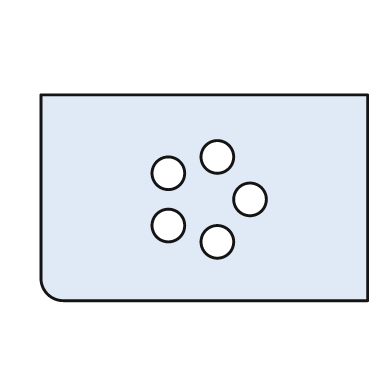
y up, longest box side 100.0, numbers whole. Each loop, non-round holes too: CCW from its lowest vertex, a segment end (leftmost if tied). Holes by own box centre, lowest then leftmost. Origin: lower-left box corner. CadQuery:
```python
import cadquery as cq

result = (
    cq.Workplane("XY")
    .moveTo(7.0, 0.0)
    .lineTo(100.0, 0.0)
    .lineTo(100.0, 63.0)
    .lineTo(0.0, 63.0)
    .lineTo(0.0, 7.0)
    .threePointArc((2.0, 2.0), (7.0, 0.0))
    .close()
    .moveTo(54.0, 18.0)
    .circle(5.0)
    .moveTo(39.0, 23.0)
    .circle(5.0)
    .moveTo(64.0, 31.0)
    .circle(5.0)
    .moveTo(39.0, 39.0)
    .circle(5.0)
    .moveTo(54.0, 44.0)
    .circle(5.0)
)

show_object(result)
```